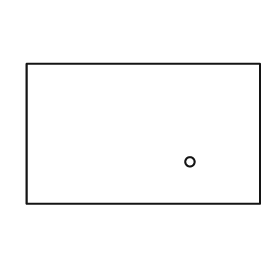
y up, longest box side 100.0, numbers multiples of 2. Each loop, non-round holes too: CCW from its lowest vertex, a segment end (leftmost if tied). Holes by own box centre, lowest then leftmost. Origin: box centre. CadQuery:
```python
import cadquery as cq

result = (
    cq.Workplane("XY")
    .moveTo(-50.0, -30.0)
    .lineTo(50.0, -30.0)
    .lineTo(50.0, 30.0)
    .lineTo(-50.0, 30.0)
    .close()
    .moveTo(20.0, -12.0)
    .circle(2.0)
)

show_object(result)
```